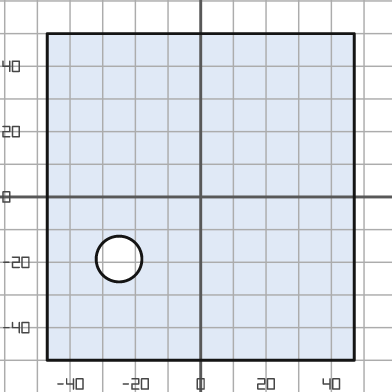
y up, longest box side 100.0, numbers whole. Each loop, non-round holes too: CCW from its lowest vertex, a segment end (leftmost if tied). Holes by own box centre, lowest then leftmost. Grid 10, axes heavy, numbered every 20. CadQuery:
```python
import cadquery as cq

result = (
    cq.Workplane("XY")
    .moveTo(-47.0, -50.0)
    .lineTo(47.0, -50.0)
    .lineTo(47.0, 50.0)
    .lineTo(-47.0, 50.0)
    .close()
    .moveTo(-25.0, -19.0)
    .circle(7.0)
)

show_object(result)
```